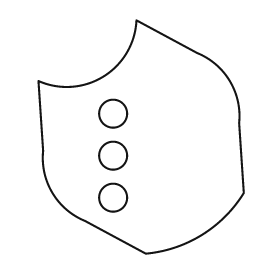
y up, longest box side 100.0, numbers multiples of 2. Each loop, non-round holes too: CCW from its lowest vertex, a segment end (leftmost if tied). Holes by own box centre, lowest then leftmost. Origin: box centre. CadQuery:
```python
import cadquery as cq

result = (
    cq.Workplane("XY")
    .moveTo(2.0, -50.0)
    .threePointArc((26.0, -42.0), (44.0, -24.0))
    .lineTo(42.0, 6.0)
    .threePointArc((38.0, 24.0), (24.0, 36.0))
    .lineTo(-2.0, 50.0)
    .threePointArc((-16.0, 26.0), (-44.0, 24.0))
    .lineTo(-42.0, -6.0)
    .threePointArc((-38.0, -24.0), (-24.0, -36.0))
    .close()
    .moveTo(-12.0, -26.0)
    .circle(6.0)
    .moveTo(-12.0, -8.0)
    .circle(6.0)
    .moveTo(-12.0, 10.0)
    .circle(6.0)
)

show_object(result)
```